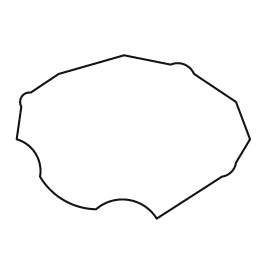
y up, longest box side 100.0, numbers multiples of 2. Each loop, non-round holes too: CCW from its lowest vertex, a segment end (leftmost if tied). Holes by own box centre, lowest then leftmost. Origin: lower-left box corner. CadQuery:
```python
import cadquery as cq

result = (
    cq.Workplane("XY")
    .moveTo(60.0, 0.0)
    .lineTo(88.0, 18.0)
    .threePointArc((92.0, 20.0), (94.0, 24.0))
    .lineTo(100.0, 34.0)
    .lineTo(94.0, 50.0)
    .lineTo(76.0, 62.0)
    .threePointArc((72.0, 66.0), (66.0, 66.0))
    .lineTo(46.0, 70.0)
    .lineTo(18.0, 62.0)
    .lineTo(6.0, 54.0)
    .threePointArc((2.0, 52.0), (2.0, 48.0))
    .lineTo(0.0, 34.0)
    .threePointArc((8.0, 28.0), (10.0, 18.0))
    .threePointArc((20.0, 8.0), (34.0, 4.0))
    .threePointArc((48.0, 8.0), (60.0, 0.0))
    .close()
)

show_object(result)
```